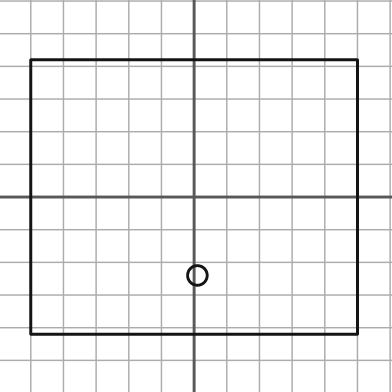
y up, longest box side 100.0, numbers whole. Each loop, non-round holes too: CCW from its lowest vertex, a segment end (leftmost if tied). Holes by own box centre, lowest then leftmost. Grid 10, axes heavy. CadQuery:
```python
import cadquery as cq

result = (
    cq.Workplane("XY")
    .moveTo(-50.0, -42.0)
    .lineTo(50.0, -42.0)
    .lineTo(50.0, 42.0)
    .lineTo(-50.0, 42.0)
    .close()
    .moveTo(1.0, -24.0)
    .circle(3.0)
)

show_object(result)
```